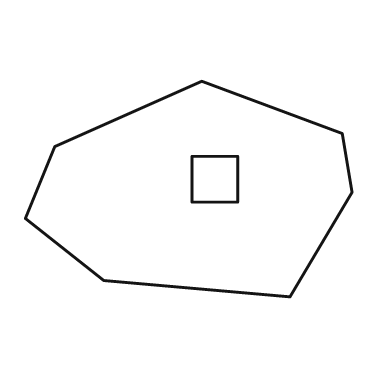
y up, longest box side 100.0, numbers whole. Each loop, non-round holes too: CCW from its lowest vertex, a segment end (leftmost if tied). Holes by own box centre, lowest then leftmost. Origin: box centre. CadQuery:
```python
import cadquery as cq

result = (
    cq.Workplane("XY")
    .moveTo(31.0, -33.0)
    .lineTo(50.0, -1.0)
    .lineTo(47.0, 17.0)
    .lineTo(4.0, 33.0)
    .lineTo(-41.0, 13.0)
    .lineTo(-50.0, -9.0)
    .lineTo(-26.0, -28.0)
    .close()
    .moveTo(1.0, -4.0)
    .lineTo(15.0, -4.0)
    .lineTo(15.0, 10.0)
    .lineTo(1.0, 10.0)
    .close()
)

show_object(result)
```